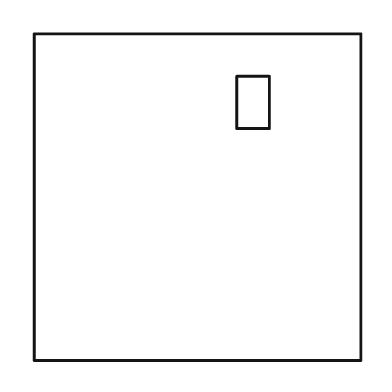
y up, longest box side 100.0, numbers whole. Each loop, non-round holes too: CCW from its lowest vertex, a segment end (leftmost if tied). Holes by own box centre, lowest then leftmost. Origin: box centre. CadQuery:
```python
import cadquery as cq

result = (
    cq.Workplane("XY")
    .moveTo(-50.0, -50.0)
    .lineTo(50.0, -50.0)
    .lineTo(50.0, 50.0)
    .lineTo(-50.0, 50.0)
    .close()
    .moveTo(12.0, 21.0)
    .lineTo(22.0, 21.0)
    .lineTo(22.0, 37.0)
    .lineTo(12.0, 37.0)
    .close()
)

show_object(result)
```